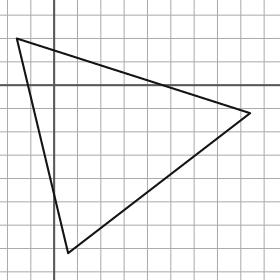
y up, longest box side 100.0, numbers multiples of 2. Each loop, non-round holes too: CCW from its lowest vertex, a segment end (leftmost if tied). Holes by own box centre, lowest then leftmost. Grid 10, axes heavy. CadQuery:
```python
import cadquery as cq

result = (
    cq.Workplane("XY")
    .moveTo(6.0, -72.0)
    .lineTo(84.0, -12.0)
    .lineTo(-16.0, 20.0)
    .close()
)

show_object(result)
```